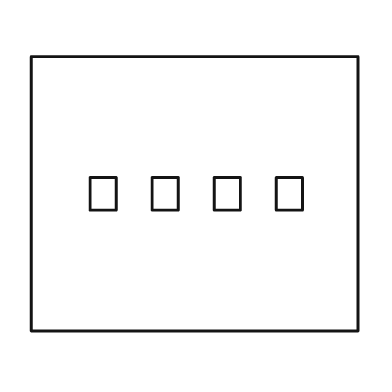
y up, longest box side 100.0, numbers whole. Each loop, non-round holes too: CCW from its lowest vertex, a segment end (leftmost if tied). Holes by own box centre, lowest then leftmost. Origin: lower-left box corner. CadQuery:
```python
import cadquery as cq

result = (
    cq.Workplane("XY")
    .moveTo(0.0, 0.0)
    .lineTo(100.0, 0.0)
    .lineTo(100.0, 84.0)
    .lineTo(0.0, 84.0)
    .close()
    .moveTo(18.0, 37.0)
    .lineTo(26.0, 37.0)
    .lineTo(26.0, 47.0)
    .lineTo(18.0, 47.0)
    .close()
    .moveTo(37.0, 37.0)
    .lineTo(45.0, 37.0)
    .lineTo(45.0, 47.0)
    .lineTo(37.0, 47.0)
    .close()
    .moveTo(56.0, 37.0)
    .lineTo(64.0, 37.0)
    .lineTo(64.0, 47.0)
    .lineTo(56.0, 47.0)
    .close()
    .moveTo(75.0, 37.0)
    .lineTo(83.0, 37.0)
    .lineTo(83.0, 47.0)
    .lineTo(75.0, 47.0)
    .close()
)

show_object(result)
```